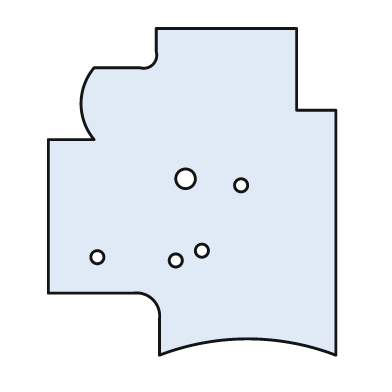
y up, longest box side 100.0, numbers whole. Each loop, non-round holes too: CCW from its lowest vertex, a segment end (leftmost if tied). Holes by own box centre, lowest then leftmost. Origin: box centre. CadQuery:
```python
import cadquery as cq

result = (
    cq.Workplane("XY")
    .moveTo(-10.0, -50.0)
    .threePointArc((17.0, -45.0), (44.0, -50.0))
    .lineTo(44.0, 25.0)
    .lineTo(32.0, 25.0)
    .lineTo(32.0, 50.0)
    .lineTo(-11.0, 50.0)
    .lineTo(-11.0, 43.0)
    .threePointArc((-12.0, 39.0), (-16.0, 38.0))
    .lineTo(-30.0, 38.0)
    .threePointArc((-34.0, 27.0), (-30.0, 16.0))
    .lineTo(-44.0, 16.0)
    .lineTo(-44.0, -31.0)
    .lineTo(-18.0, -31.0)
    .threePointArc((-12.0, -33.0), (-10.0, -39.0))
    .close()
    .moveTo(-5.0, -21.0)
    .circle(2.0)
    .moveTo(-29.0, -20.0)
    .circle(2.0)
    .moveTo(3.0, -18.0)
    .circle(2.0)
    .moveTo(15.0, 2.0)
    .circle(2.0)
    .moveTo(-2.0, 4.0)
    .circle(3.0)
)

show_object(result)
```